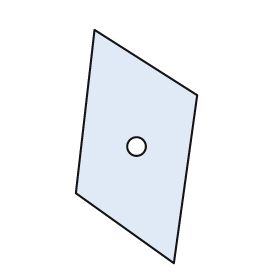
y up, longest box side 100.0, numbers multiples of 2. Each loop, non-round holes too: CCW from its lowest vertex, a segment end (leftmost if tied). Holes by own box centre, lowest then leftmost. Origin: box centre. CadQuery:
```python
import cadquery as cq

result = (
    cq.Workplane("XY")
    .moveTo(16.0, -50.0)
    .lineTo(26.0, 22.0)
    .lineTo(-18.0, 50.0)
    .lineTo(-26.0, -20.0)
    .close()
    .moveTo(0.0, 0.0)
    .circle(4.0)
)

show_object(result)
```